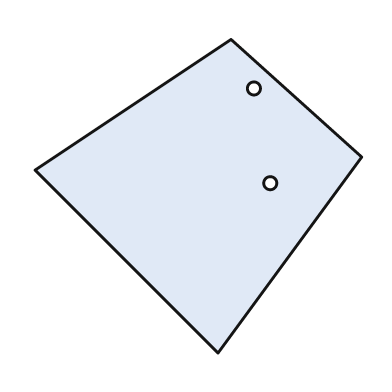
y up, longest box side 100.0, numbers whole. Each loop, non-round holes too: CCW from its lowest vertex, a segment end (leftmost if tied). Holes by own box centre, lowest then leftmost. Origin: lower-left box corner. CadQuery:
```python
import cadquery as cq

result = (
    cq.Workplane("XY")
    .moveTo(56.0, 0.0)
    .lineTo(100.0, 60.0)
    .lineTo(60.0, 96.0)
    .lineTo(0.0, 56.0)
    .close()
    .moveTo(72.0, 52.0)
    .circle(2.0)
    .moveTo(67.0, 81.0)
    .circle(2.0)
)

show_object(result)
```